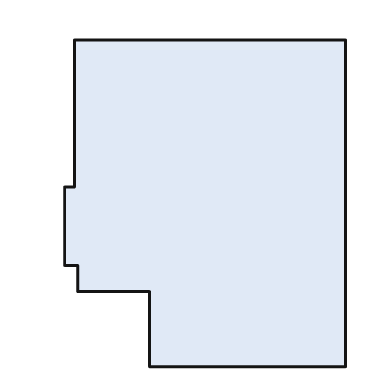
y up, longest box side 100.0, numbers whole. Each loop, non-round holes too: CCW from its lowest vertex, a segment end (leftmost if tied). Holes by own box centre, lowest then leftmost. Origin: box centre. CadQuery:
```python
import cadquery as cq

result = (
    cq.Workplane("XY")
    .moveTo(-17.0, -50.0)
    .lineTo(43.0, -50.0)
    .lineTo(43.0, 50.0)
    .lineTo(-40.0, 50.0)
    .lineTo(-40.0, 5.0)
    .lineTo(-43.0, 5.0)
    .lineTo(-43.0, -19.0)
    .lineTo(-39.0, -19.0)
    .lineTo(-39.0, -27.0)
    .lineTo(-17.0, -27.0)
    .close()
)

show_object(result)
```